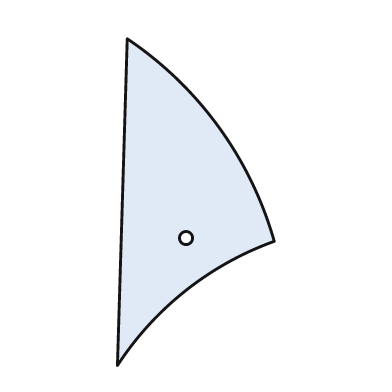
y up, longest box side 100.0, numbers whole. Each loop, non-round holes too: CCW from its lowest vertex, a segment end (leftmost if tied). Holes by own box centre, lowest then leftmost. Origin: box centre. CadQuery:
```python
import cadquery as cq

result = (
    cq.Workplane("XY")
    .moveTo(-24.0, -50.0)
    .threePointArc((-3.0, -27.0), (24.0, -12.0))
    .threePointArc((7.0, 23.0), (-21.0, 50.0))
    .close()
    .moveTo(-3.0, -11.0)
    .circle(2.0)
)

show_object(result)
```